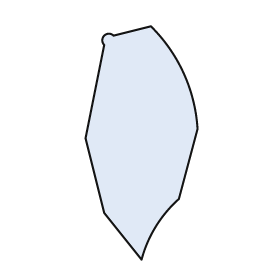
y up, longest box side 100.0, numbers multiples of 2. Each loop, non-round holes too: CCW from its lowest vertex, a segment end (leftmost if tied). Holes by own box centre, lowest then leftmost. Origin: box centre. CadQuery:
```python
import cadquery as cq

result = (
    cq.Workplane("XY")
    .moveTo(0.0, -50.0)
    .threePointArc((6.0, -36.0), (16.0, -24.0))
    .lineTo(24.0, 6.0)
    .threePointArc((18.0, 30.0), (4.0, 50.0))
    .lineTo(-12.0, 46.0)
    .threePointArc((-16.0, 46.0), (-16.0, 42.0))
    .lineTo(-24.0, 2.0)
    .lineTo(-16.0, -30.0)
    .close()
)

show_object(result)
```